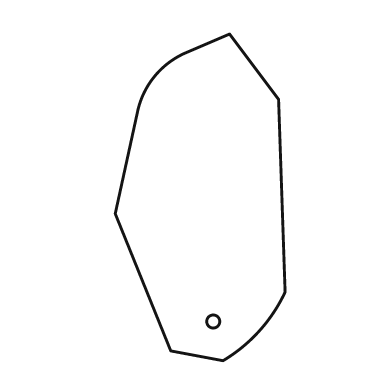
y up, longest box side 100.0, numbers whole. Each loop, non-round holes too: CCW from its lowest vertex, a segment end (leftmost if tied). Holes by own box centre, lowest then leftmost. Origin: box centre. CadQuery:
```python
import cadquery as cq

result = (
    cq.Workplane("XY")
    .moveTo(7.0, -50.0)
    .threePointArc((18.0, -41.0), (26.0, -29.0))
    .lineTo(24.0, 30.0)
    .lineTo(9.0, 50.0)
    .lineTo(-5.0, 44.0)
    .threePointArc((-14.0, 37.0), (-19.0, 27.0))
    .lineTo(-26.0, -5.0)
    .lineTo(-9.0, -47.0)
    .close()
    .moveTo(4.0, -38.0)
    .circle(2.0)
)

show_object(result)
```